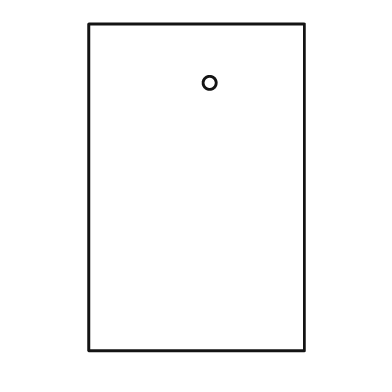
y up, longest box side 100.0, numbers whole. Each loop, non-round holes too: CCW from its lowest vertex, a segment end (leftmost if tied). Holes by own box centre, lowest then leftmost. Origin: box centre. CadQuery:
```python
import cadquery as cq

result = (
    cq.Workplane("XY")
    .moveTo(-33.0, -50.0)
    .lineTo(33.0, -50.0)
    .lineTo(33.0, 50.0)
    .lineTo(-33.0, 50.0)
    .close()
    .moveTo(4.0, 32.0)
    .circle(2.0)
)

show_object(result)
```